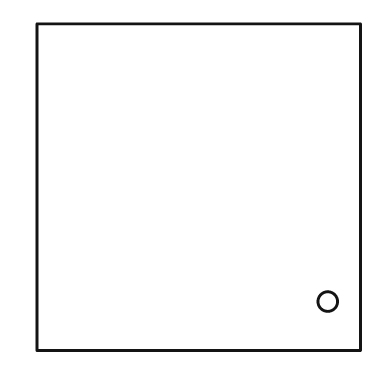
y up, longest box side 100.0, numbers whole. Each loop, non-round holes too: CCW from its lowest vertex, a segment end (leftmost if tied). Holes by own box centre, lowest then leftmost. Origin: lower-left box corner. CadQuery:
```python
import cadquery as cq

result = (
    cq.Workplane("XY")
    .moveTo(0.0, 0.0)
    .lineTo(99.0, 0.0)
    .lineTo(99.0, 100.0)
    .lineTo(0.0, 100.0)
    .close()
    .moveTo(89.0, 15.0)
    .circle(3.0)
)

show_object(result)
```